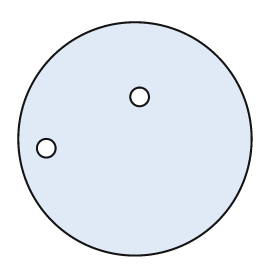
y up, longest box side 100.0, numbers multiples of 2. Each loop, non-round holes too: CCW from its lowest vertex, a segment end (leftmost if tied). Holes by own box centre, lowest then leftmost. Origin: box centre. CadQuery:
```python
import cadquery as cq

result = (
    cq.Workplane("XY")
    .moveTo(0.0, 0.0)
    .circle(50.0)
    .moveTo(-38.0, -4.0)
    .circle(4.0)
    .moveTo(2.0, 18.0)
    .circle(4.0)
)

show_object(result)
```